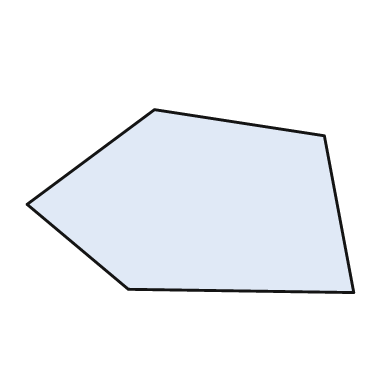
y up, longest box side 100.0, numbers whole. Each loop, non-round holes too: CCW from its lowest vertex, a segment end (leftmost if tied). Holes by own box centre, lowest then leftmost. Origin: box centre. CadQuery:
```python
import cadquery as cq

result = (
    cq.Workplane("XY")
    .moveTo(50.0, -28.0)
    .lineTo(41.0, 20.0)
    .lineTo(-11.0, 28.0)
    .lineTo(-50.0, -1.0)
    .lineTo(-19.0, -27.0)
    .close()
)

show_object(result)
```